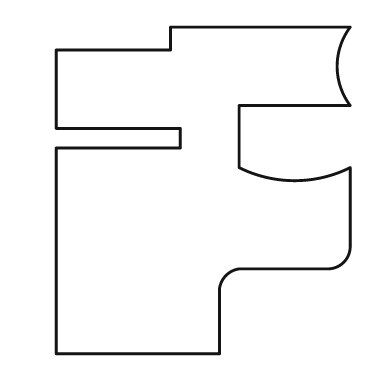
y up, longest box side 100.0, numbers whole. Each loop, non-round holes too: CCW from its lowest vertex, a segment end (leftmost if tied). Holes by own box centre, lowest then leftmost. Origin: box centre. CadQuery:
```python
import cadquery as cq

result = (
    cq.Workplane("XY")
    .moveTo(-45.0, -50.0)
    .lineTo(5.0, -50.0)
    .lineTo(5.0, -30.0)
    .threePointArc((7.0, -26.0), (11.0, -24.0))
    .lineTo(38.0, -24.0)
    .threePointArc((43.0, -22.0), (45.0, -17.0))
    .lineTo(45.0, 7.0)
    .threePointArc((28.0, 3.0), (11.0, 7.0))
    .lineTo(11.0, 26.0)
    .lineTo(45.0, 26.0)
    .threePointArc((41.0, 38.0), (45.0, 50.0))
    .lineTo(-10.0, 50.0)
    .lineTo(-10.0, 43.0)
    .lineTo(-45.0, 43.0)
    .lineTo(-45.0, 19.0)
    .lineTo(-7.0, 19.0)
    .lineTo(-7.0, 13.0)
    .lineTo(-45.0, 13.0)
    .close()
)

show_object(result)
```